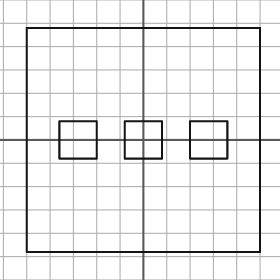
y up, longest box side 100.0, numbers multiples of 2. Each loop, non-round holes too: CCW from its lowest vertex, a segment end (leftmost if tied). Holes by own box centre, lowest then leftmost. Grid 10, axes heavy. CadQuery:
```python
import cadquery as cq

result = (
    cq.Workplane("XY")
    .moveTo(-50.0, -48.0)
    .lineTo(50.0, -48.0)
    .lineTo(50.0, 48.0)
    .lineTo(-50.0, 48.0)
    .close()
    .moveTo(-36.0, -8.0)
    .lineTo(-20.0, -8.0)
    .lineTo(-20.0, 8.0)
    .lineTo(-36.0, 8.0)
    .close()
    .moveTo(-8.0, -8.0)
    .lineTo(8.0, -8.0)
    .lineTo(8.0, 8.0)
    .lineTo(-8.0, 8.0)
    .close()
    .moveTo(20.0, -8.0)
    .lineTo(36.0, -8.0)
    .lineTo(36.0, 8.0)
    .lineTo(20.0, 8.0)
    .close()
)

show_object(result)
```